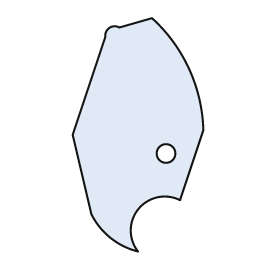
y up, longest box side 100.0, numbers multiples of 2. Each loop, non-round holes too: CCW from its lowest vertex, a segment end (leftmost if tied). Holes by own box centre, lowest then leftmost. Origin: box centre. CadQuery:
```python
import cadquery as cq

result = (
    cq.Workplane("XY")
    .moveTo(0.0, -50.0)
    .threePointArc((0.0, -32.0), (18.0, -28.0))
    .lineTo(28.0, 2.0)
    .threePointArc((22.0, 28.0), (6.0, 50.0))
    .lineTo(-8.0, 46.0)
    .threePointArc((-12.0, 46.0), (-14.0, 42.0))
    .lineTo(-28.0, 0.0)
    .lineTo(-20.0, -34.0)
    .threePointArc((-12.0, -44.0), (0.0, -50.0))
    .close()
    .moveTo(12.0, -8.0)
    .circle(4.0)
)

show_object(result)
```